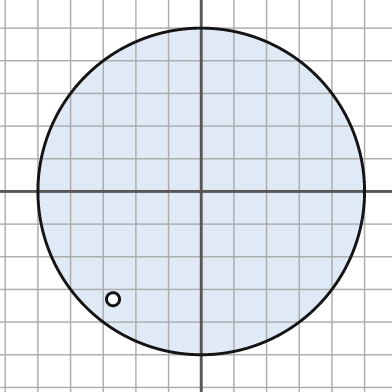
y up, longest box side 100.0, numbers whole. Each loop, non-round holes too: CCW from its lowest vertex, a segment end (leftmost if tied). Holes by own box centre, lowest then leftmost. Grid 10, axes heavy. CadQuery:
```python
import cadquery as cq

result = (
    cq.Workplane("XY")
    .moveTo(0.0, 0.0)
    .circle(50.0)
    .moveTo(-27.0, -33.0)
    .circle(2.0)
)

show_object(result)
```